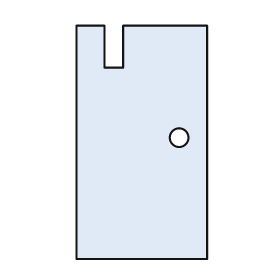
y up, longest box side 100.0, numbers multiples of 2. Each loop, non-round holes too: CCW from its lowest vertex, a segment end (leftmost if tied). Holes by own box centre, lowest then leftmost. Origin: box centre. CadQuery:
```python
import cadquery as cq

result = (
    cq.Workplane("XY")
    .moveTo(-28.0, -50.0)
    .lineTo(28.0, -50.0)
    .lineTo(28.0, 50.0)
    .lineTo(-8.0, 50.0)
    .lineTo(-8.0, 32.0)
    .lineTo(-16.0, 32.0)
    .lineTo(-16.0, 50.0)
    .lineTo(-28.0, 50.0)
    .close()
    .moveTo(16.0, 2.0)
    .circle(4.0)
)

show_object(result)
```